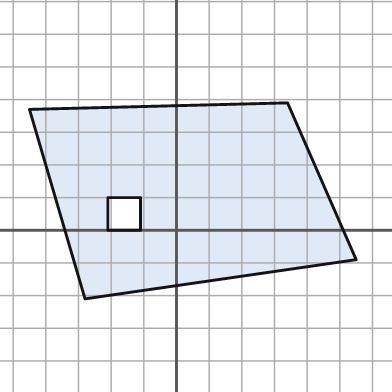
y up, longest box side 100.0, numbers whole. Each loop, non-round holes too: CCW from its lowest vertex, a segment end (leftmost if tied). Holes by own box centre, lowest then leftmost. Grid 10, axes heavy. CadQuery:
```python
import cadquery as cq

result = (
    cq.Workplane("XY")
    .moveTo(-28.0, -21.0)
    .lineTo(55.0, -9.0)
    .lineTo(34.0, 39.0)
    .lineTo(-45.0, 37.0)
    .close()
    .moveTo(-21.0, 0.0)
    .lineTo(-11.0, 0.0)
    .lineTo(-11.0, 10.0)
    .lineTo(-21.0, 10.0)
    .close()
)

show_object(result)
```